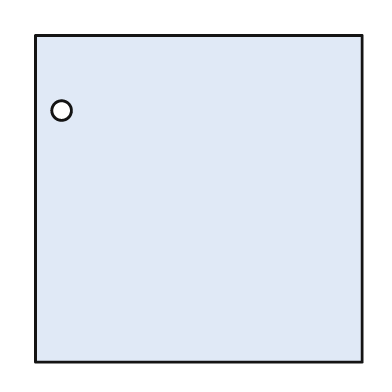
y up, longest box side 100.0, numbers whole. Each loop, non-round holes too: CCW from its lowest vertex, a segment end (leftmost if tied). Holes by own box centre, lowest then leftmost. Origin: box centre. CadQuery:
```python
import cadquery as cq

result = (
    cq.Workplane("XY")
    .moveTo(-50.0, -50.0)
    .lineTo(50.0, -50.0)
    .lineTo(50.0, 50.0)
    .lineTo(-50.0, 50.0)
    .close()
    .moveTo(-42.0, 27.0)
    .circle(3.0)
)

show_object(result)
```